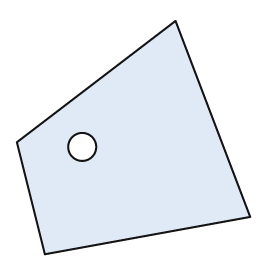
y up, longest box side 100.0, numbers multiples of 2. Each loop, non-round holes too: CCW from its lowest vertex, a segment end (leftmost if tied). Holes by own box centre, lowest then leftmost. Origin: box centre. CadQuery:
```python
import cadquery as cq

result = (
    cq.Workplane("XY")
    .moveTo(-38.0, -50.0)
    .lineTo(50.0, -34.0)
    .lineTo(18.0, 50.0)
    .lineTo(-50.0, -2.0)
    .close()
    .moveTo(-22.0, -4.0)
    .circle(6.0)
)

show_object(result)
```